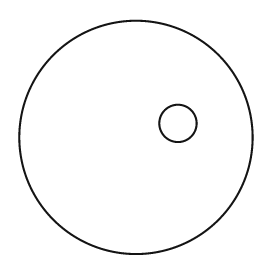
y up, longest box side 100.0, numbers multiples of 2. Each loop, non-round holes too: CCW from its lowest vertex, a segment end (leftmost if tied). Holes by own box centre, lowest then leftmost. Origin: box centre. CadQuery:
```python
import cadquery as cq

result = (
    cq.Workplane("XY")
    .moveTo(0.0, 0.0)
    .circle(50.0)
    .moveTo(18.0, 6.0)
    .circle(8.0)
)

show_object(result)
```